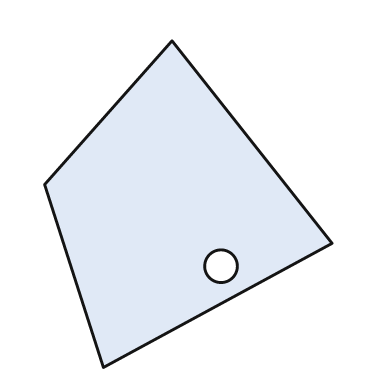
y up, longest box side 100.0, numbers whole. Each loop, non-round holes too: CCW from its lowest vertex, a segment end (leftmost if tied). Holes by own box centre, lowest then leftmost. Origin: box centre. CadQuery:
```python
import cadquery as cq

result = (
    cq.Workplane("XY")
    .moveTo(-26.0, -50.0)
    .lineTo(44.0, -12.0)
    .lineTo(-5.0, 50.0)
    .lineTo(-44.0, 6.0)
    .close()
    .moveTo(10.0, -19.0)
    .circle(5.0)
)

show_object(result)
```